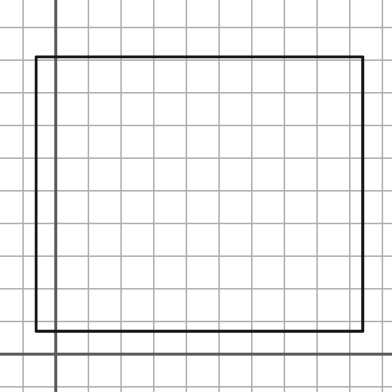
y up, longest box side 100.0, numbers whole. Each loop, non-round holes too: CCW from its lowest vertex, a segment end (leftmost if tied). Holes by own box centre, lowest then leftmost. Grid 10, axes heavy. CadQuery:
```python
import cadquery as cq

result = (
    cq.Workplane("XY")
    .moveTo(-6.0, 7.0)
    .lineTo(94.0, 7.0)
    .lineTo(94.0, 91.0)
    .lineTo(-6.0, 91.0)
    .close()
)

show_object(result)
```